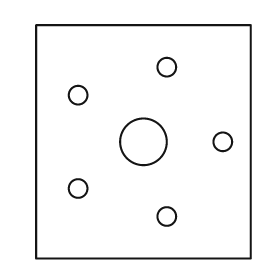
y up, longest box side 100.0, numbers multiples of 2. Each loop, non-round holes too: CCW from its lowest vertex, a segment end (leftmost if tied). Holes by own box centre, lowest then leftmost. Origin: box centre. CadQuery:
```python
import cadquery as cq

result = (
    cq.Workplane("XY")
    .moveTo(-46.0, -50.0)
    .lineTo(46.0, -50.0)
    .lineTo(46.0, 50.0)
    .lineTo(-46.0, 50.0)
    .close()
    .moveTo(10.0, -32.0)
    .circle(4.0)
    .moveTo(-28.0, -20.0)
    .circle(4.0)
    .moveTo(0.0, 0.0)
    .circle(10.0)
    .moveTo(34.0, 0.0)
    .circle(4.0)
    .moveTo(-28.0, 20.0)
    .circle(4.0)
    .moveTo(10.0, 32.0)
    .circle(4.0)
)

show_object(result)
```